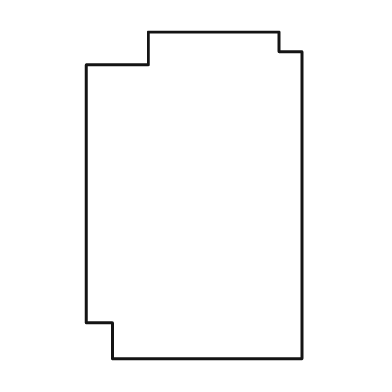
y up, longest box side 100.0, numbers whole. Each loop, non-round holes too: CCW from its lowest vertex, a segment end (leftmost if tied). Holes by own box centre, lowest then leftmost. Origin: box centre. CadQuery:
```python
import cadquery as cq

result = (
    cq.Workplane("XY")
    .moveTo(-25.0, -50.0)
    .lineTo(33.0, -50.0)
    .lineTo(33.0, 44.0)
    .lineTo(26.0, 44.0)
    .lineTo(26.0, 50.0)
    .lineTo(-14.0, 50.0)
    .lineTo(-14.0, 40.0)
    .lineTo(-33.0, 40.0)
    .lineTo(-33.0, -39.0)
    .lineTo(-25.0, -39.0)
    .close()
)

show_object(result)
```